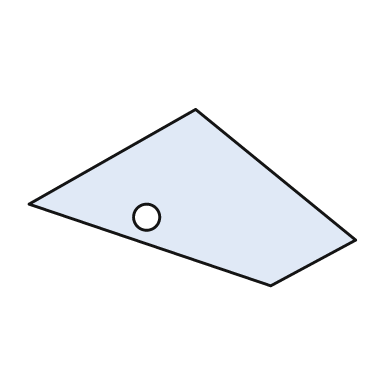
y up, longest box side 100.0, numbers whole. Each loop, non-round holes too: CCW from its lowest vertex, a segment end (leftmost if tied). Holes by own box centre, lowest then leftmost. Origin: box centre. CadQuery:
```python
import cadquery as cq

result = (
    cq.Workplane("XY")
    .moveTo(24.0, -27.0)
    .lineTo(50.0, -13.0)
    .lineTo(1.0, 27.0)
    .lineTo(-50.0, -2.0)
    .close()
    .moveTo(-14.0, -6.0)
    .circle(4.0)
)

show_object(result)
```